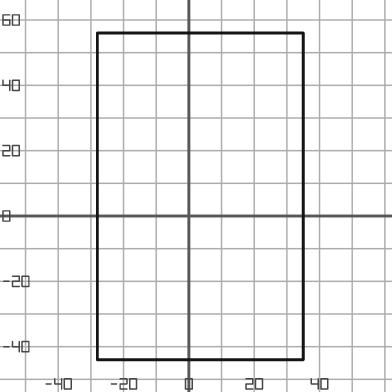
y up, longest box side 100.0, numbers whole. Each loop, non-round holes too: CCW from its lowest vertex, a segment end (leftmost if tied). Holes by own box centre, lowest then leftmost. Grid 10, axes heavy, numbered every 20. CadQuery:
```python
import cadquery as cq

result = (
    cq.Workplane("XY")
    .moveTo(-28.0, -44.0)
    .lineTo(35.0, -44.0)
    .lineTo(35.0, 56.0)
    .lineTo(-28.0, 56.0)
    .close()
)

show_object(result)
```